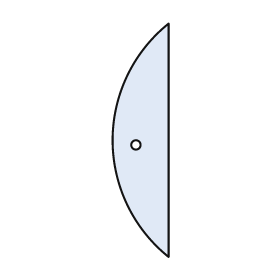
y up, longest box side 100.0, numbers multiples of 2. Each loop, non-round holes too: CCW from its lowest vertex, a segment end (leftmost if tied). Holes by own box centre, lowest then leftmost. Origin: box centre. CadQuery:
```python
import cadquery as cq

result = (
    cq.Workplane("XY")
    .moveTo(12.0, -50.0)
    .lineTo(12.0, 50.0)
    .threePointArc((-12.0, 0.0), (12.0, -50.0))
    .close()
    .moveTo(-2.0, -2.0)
    .circle(2.0)
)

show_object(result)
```